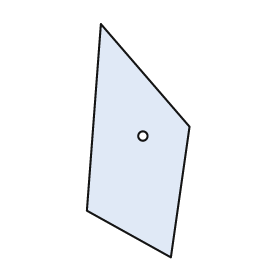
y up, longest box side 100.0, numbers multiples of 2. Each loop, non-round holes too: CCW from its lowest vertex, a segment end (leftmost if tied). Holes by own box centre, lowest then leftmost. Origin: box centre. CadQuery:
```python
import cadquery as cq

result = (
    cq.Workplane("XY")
    .moveTo(14.0, -50.0)
    .lineTo(22.0, 6.0)
    .lineTo(-16.0, 50.0)
    .lineTo(-22.0, -30.0)
    .close()
    .moveTo(2.0, 2.0)
    .circle(2.0)
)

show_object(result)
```